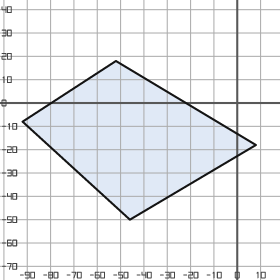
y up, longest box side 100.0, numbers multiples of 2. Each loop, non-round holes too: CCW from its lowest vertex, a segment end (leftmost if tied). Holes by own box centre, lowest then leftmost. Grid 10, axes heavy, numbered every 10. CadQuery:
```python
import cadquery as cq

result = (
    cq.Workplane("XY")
    .moveTo(-46.0, -50.0)
    .lineTo(8.0, -18.0)
    .lineTo(-52.0, 18.0)
    .lineTo(-92.0, -8.0)
    .close()
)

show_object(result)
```